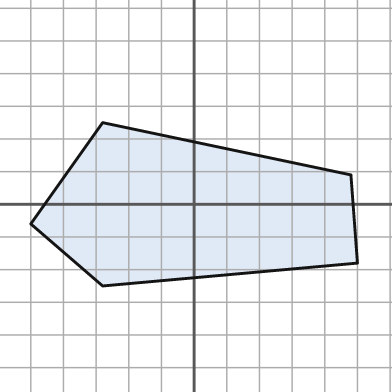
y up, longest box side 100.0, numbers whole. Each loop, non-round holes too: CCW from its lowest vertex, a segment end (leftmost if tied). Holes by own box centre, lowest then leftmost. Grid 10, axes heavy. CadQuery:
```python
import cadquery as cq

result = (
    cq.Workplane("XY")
    .moveTo(-28.0, -25.0)
    .lineTo(50.0, -18.0)
    .lineTo(48.0, 9.0)
    .lineTo(-28.0, 25.0)
    .lineTo(-50.0, -6.0)
    .close()
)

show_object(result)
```